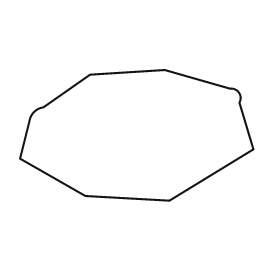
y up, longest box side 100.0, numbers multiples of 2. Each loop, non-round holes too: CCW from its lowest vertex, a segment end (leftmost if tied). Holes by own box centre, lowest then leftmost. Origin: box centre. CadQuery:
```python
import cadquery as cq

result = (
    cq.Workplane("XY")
    .moveTo(14.0, -28.0)
    .lineTo(50.0, -6.0)
    .lineTo(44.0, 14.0)
    .threePointArc((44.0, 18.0), (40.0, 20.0))
    .lineTo(12.0, 28.0)
    .lineTo(-20.0, 26.0)
    .lineTo(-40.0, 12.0)
    .threePointArc((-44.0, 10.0), (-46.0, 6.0))
    .lineTo(-50.0, -10.0)
    .lineTo(-22.0, -26.0)
    .close()
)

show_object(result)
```